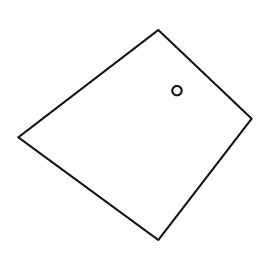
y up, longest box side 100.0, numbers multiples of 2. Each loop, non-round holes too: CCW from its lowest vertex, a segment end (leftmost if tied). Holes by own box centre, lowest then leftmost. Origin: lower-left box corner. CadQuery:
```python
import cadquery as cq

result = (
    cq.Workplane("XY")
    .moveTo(60.0, 0.0)
    .lineTo(100.0, 52.0)
    .lineTo(60.0, 90.0)
    .lineTo(0.0, 44.0)
    .close()
    .moveTo(68.0, 64.0)
    .circle(2.0)
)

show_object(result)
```